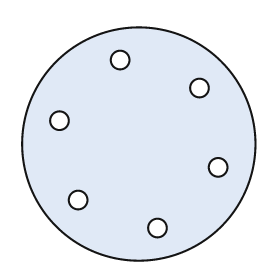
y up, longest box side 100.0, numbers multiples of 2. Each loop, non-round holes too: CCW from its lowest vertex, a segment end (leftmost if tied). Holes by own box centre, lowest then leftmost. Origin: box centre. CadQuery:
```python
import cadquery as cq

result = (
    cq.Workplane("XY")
    .moveTo(0.0, 0.0)
    .circle(50.0)
    .moveTo(8.0, -36.0)
    .circle(4.0)
    .moveTo(-26.0, -24.0)
    .circle(4.0)
    .moveTo(34.0, -10.0)
    .circle(4.0)
    .moveTo(-34.0, 10.0)
    .circle(4.0)
    .moveTo(26.0, 24.0)
    .circle(4.0)
    .moveTo(-8.0, 36.0)
    .circle(4.0)
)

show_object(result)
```